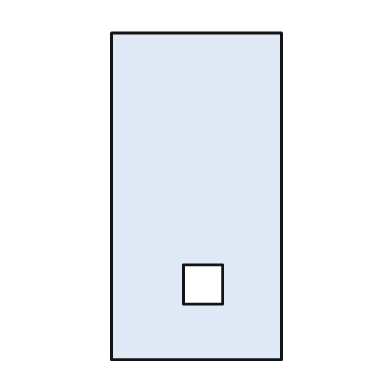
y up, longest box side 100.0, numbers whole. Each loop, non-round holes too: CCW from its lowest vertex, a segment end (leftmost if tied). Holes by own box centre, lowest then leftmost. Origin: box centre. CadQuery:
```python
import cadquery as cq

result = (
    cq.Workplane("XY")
    .moveTo(-26.0, -50.0)
    .lineTo(26.0, -50.0)
    .lineTo(26.0, 50.0)
    .lineTo(-26.0, 50.0)
    .close()
    .moveTo(-4.0, -33.0)
    .lineTo(8.0, -33.0)
    .lineTo(8.0, -21.0)
    .lineTo(-4.0, -21.0)
    .close()
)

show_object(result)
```